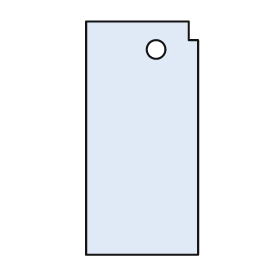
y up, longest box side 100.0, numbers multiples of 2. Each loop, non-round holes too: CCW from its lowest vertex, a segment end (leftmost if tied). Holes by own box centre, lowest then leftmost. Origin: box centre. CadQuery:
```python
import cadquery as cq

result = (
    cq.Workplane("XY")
    .moveTo(-24.0, -50.0)
    .lineTo(24.0, -50.0)
    .lineTo(24.0, 42.0)
    .lineTo(20.0, 42.0)
    .lineTo(20.0, 50.0)
    .lineTo(-24.0, 50.0)
    .close()
    .moveTo(6.0, 38.0)
    .circle(4.0)
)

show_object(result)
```